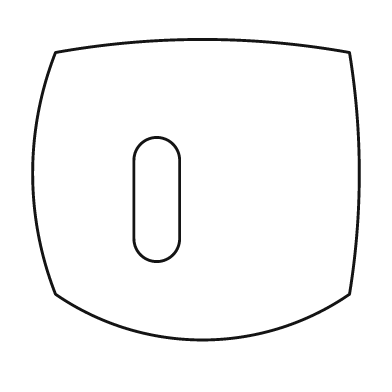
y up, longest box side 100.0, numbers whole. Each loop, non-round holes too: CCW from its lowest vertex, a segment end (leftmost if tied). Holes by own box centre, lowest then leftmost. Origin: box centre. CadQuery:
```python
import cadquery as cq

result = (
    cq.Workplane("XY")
    .moveTo(-43.0, -32.0)
    .threePointArc((2.0, -46.0), (47.0, -32.0))
    .threePointArc((50.0, 5.0), (47.0, 42.0))
    .threePointArc((2.0, 46.0), (-43.0, 42.0))
    .threePointArc((-50.0, 5.0), (-43.0, -32.0))
    .close()
    .moveTo(-19.0, -15.0)
    .threePointArc((-12.0, -22.0), (-5.0, -15.0))
    .lineTo(-5.0, 9.0)
    .threePointArc((-12.0, 16.0), (-19.0, 9.0))
    .close()
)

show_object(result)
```